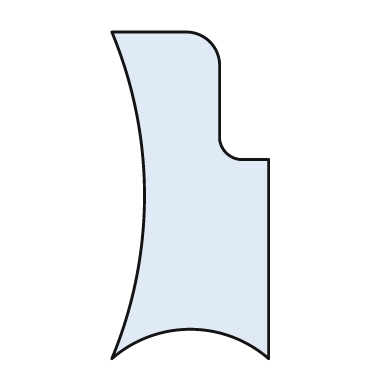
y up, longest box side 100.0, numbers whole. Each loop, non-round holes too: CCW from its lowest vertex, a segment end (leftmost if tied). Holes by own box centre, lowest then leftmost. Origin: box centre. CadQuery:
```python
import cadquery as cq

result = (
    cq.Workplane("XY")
    .moveTo(-24.0, -50.0)
    .threePointArc((0.0, -41.0), (24.0, -50.0))
    .lineTo(24.0, 11.0)
    .lineTo(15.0, 11.0)
    .threePointArc((11.0, 13.0), (9.0, 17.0))
    .lineTo(9.0, 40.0)
    .threePointArc((6.0, 47.0), (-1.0, 50.0))
    .lineTo(-24.0, 50.0)
    .threePointArc((-14.0, 0.0), (-24.0, -50.0))
    .close()
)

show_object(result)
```